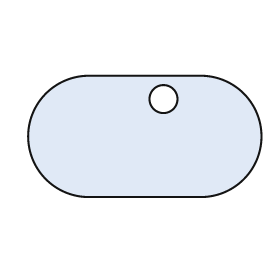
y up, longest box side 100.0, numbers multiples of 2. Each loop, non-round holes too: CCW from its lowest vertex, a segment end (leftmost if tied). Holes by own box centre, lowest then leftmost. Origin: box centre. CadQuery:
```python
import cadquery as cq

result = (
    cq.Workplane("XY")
    .moveTo(-24.0, -26.0)
    .lineTo(24.0, -26.0)
    .threePointArc((50.0, 0.0), (24.0, 26.0))
    .lineTo(-24.0, 26.0)
    .threePointArc((-50.0, 0.0), (-24.0, -26.0))
    .close()
    .moveTo(8.0, 16.0)
    .circle(6.0)
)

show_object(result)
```